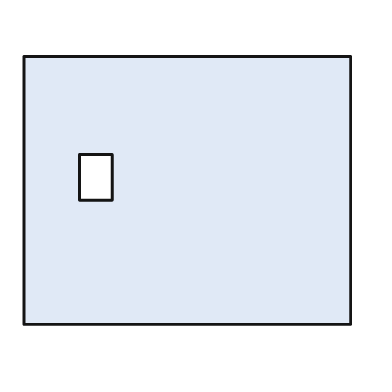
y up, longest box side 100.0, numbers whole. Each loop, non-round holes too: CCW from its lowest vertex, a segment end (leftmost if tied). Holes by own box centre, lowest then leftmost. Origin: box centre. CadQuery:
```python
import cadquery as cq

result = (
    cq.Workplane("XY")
    .moveTo(-50.0, -41.0)
    .lineTo(50.0, -41.0)
    .lineTo(50.0, 41.0)
    .lineTo(-50.0, 41.0)
    .close()
    .moveTo(-33.0, -3.0)
    .lineTo(-23.0, -3.0)
    .lineTo(-23.0, 11.0)
    .lineTo(-33.0, 11.0)
    .close()
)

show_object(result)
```